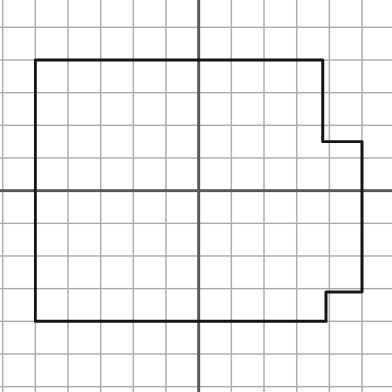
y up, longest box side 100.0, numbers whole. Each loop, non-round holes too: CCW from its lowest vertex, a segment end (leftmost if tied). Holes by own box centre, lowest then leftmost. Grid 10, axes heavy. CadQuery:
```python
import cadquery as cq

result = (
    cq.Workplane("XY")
    .moveTo(-50.0, -40.0)
    .lineTo(39.0, -40.0)
    .lineTo(39.0, -31.0)
    .lineTo(50.0, -31.0)
    .lineTo(50.0, 15.0)
    .lineTo(38.0, 15.0)
    .lineTo(38.0, 40.0)
    .lineTo(-50.0, 40.0)
    .close()
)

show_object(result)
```